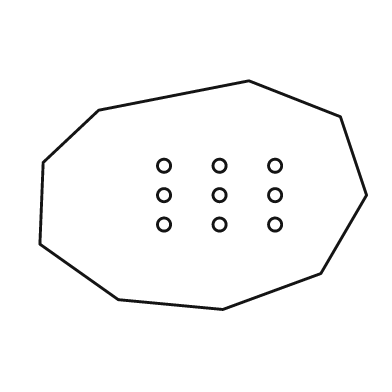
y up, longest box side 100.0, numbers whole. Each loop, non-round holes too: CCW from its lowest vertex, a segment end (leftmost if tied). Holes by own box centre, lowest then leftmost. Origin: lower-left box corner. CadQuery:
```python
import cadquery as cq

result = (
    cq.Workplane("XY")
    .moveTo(56.0, 0.0)
    .lineTo(86.0, 11.0)
    .lineTo(100.0, 35.0)
    .lineTo(92.0, 59.0)
    .lineTo(64.0, 70.0)
    .lineTo(18.0, 61.0)
    .lineTo(1.0, 45.0)
    .lineTo(0.0, 20.0)
    .lineTo(24.0, 3.0)
    .close()
    .moveTo(38.0, 26.0)
    .circle(2.0)
    .moveTo(55.0, 26.0)
    .circle(2.0)
    .moveTo(72.0, 26.0)
    .circle(2.0)
    .moveTo(38.0, 35.0)
    .circle(2.0)
    .moveTo(55.0, 35.0)
    .circle(2.0)
    .moveTo(72.0, 35.0)
    .circle(2.0)
    .moveTo(38.0, 44.0)
    .circle(2.0)
    .moveTo(55.0, 44.0)
    .circle(2.0)
    .moveTo(72.0, 44.0)
    .circle(2.0)
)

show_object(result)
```